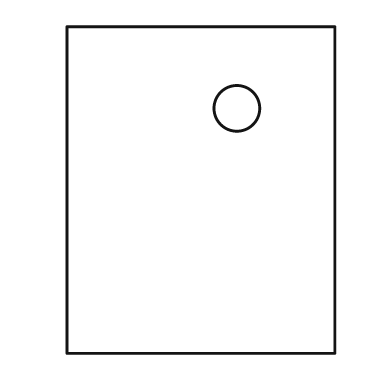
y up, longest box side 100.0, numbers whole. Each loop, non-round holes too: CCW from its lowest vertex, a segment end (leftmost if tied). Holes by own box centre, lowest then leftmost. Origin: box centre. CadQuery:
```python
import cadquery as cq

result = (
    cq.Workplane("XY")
    .moveTo(-41.0, -50.0)
    .lineTo(41.0, -50.0)
    .lineTo(41.0, 50.0)
    .lineTo(-41.0, 50.0)
    .close()
    .moveTo(11.0, 25.0)
    .circle(7.0)
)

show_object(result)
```